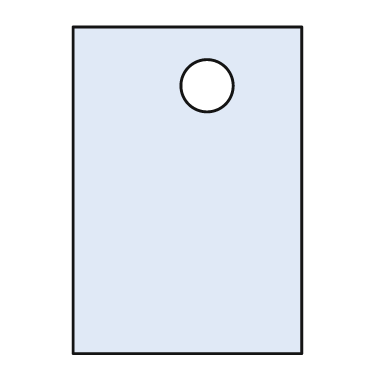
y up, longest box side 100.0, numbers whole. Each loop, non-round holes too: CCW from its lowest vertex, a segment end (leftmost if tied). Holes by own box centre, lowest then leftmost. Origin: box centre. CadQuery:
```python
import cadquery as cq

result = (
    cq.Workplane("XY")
    .moveTo(-35.0, -50.0)
    .lineTo(35.0, -50.0)
    .lineTo(35.0, 50.0)
    .lineTo(-35.0, 50.0)
    .close()
    .moveTo(6.0, 32.0)
    .circle(8.0)
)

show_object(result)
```